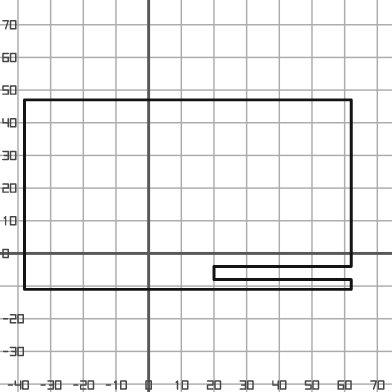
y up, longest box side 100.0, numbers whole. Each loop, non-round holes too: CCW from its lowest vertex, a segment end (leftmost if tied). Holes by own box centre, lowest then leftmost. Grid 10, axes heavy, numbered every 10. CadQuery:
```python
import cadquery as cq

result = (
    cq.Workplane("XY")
    .moveTo(-38.0, -11.0)
    .lineTo(62.0, -11.0)
    .lineTo(62.0, -8.0)
    .lineTo(20.0, -8.0)
    .lineTo(20.0, -4.0)
    .lineTo(62.0, -4.0)
    .lineTo(62.0, 47.0)
    .lineTo(-38.0, 47.0)
    .close()
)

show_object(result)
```